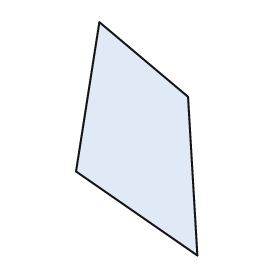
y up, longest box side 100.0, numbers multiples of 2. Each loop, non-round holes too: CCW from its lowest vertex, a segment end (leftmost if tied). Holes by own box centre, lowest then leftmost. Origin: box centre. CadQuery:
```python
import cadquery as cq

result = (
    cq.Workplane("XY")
    .moveTo(26.0, -50.0)
    .lineTo(22.0, 18.0)
    .lineTo(-16.0, 50.0)
    .lineTo(-26.0, -14.0)
    .close()
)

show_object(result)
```